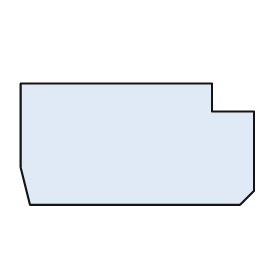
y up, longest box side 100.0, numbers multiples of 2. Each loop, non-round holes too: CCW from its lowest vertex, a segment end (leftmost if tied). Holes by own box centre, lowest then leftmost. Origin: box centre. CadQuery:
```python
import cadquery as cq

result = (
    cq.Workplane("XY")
    .moveTo(-46.0, -26.0)
    .lineTo(44.0, -26.0)
    .lineTo(50.0, -20.0)
    .lineTo(50.0, 14.0)
    .lineTo(32.0, 14.0)
    .lineTo(32.0, 26.0)
    .lineTo(-50.0, 26.0)
    .lineTo(-50.0, -10.0)
    .close()
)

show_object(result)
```